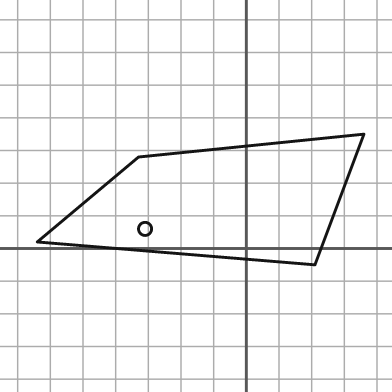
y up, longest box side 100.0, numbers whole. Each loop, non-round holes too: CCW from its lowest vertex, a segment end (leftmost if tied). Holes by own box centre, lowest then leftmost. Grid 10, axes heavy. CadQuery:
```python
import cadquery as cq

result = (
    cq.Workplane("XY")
    .moveTo(21.0, -5.0)
    .lineTo(36.0, 35.0)
    .lineTo(-33.0, 28.0)
    .lineTo(-64.0, 2.0)
    .close()
    .moveTo(-31.0, 6.0)
    .circle(2.0)
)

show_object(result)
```